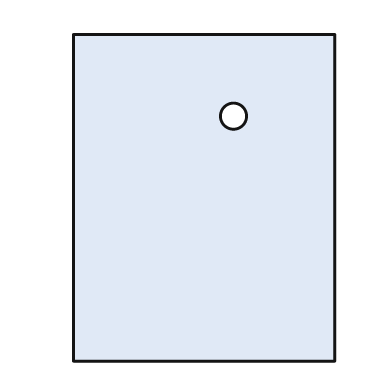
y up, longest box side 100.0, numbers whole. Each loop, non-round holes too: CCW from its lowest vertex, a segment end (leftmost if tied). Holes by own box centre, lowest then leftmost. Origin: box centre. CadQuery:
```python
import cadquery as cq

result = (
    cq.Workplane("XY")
    .moveTo(-40.0, -50.0)
    .lineTo(40.0, -50.0)
    .lineTo(40.0, 50.0)
    .lineTo(-40.0, 50.0)
    .close()
    .moveTo(9.0, 25.0)
    .circle(4.0)
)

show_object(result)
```